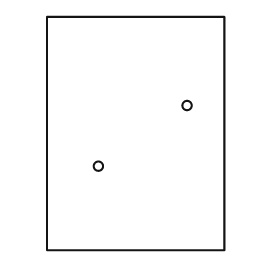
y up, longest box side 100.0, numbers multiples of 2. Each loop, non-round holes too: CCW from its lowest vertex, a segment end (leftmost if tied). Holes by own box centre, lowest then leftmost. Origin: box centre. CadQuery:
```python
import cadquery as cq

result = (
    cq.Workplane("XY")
    .moveTo(-38.0, -50.0)
    .lineTo(38.0, -50.0)
    .lineTo(38.0, 50.0)
    .lineTo(-38.0, 50.0)
    .close()
    .moveTo(-16.0, -14.0)
    .circle(2.0)
    .moveTo(22.0, 12.0)
    .circle(2.0)
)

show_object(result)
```